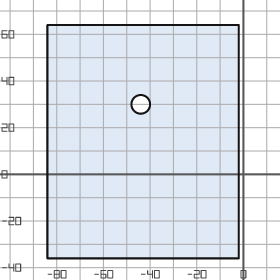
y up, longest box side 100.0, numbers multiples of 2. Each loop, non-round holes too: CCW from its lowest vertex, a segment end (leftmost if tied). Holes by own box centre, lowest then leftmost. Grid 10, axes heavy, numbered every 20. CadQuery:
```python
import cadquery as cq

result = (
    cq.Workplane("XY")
    .moveTo(-84.0, -36.0)
    .lineTo(-2.0, -36.0)
    .lineTo(-2.0, 64.0)
    .lineTo(-84.0, 64.0)
    .close()
    .moveTo(-44.0, 30.0)
    .circle(4.0)
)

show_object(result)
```